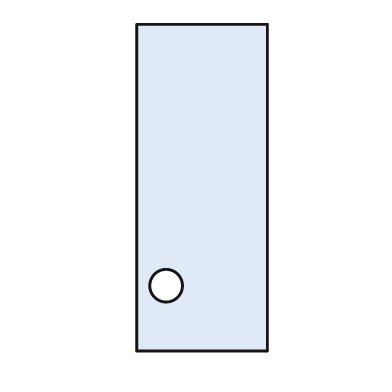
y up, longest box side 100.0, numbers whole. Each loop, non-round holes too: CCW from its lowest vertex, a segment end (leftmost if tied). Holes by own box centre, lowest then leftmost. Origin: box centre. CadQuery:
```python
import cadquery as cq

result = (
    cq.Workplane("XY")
    .moveTo(-20.0, -50.0)
    .lineTo(20.0, -50.0)
    .lineTo(20.0, 50.0)
    .lineTo(-20.0, 50.0)
    .close()
    .moveTo(-11.0, -30.0)
    .circle(5.0)
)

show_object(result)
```